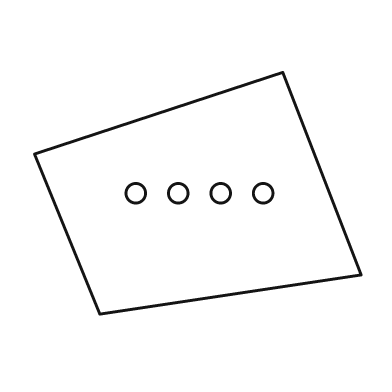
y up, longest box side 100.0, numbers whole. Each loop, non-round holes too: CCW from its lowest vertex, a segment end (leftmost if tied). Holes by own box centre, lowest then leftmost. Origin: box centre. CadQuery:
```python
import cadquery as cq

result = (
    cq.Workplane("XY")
    .moveTo(-30.0, -37.0)
    .lineTo(50.0, -25.0)
    .lineTo(26.0, 37.0)
    .lineTo(-50.0, 12.0)
    .close()
    .moveTo(-19.0, 0.0)
    .circle(3.0)
    .moveTo(-6.0, 0.0)
    .circle(3.0)
    .moveTo(7.0, 0.0)
    .circle(3.0)
    .moveTo(20.0, 0.0)
    .circle(3.0)
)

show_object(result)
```